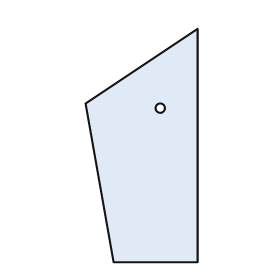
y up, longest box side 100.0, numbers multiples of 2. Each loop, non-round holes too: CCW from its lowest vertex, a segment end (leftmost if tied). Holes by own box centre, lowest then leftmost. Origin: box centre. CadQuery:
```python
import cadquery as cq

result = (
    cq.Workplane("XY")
    .moveTo(-12.0, -50.0)
    .lineTo(24.0, -50.0)
    .lineTo(24.0, 50.0)
    .lineTo(-24.0, 18.0)
    .close()
    .moveTo(8.0, 16.0)
    .circle(2.0)
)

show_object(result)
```